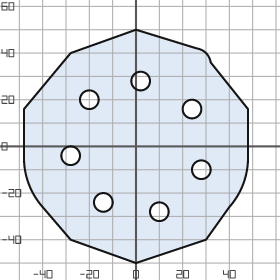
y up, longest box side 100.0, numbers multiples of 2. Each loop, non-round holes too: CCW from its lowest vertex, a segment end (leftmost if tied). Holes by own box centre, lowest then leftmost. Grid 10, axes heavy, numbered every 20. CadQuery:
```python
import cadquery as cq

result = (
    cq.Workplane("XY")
    .moveTo(0.0, -50.0)
    .lineTo(30.0, -40.0)
    .lineTo(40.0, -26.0)
    .threePointArc((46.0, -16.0), (48.0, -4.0))
    .lineTo(48.0, 16.0)
    .lineTo(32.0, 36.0)
    .threePointArc((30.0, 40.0), (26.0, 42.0))
    .lineTo(0.0, 50.0)
    .lineTo(-28.0, 40.0)
    .lineTo(-48.0, 16.0)
    .lineTo(-48.0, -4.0)
    .threePointArc((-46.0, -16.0), (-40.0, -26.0))
    .lineTo(-28.0, -40.0)
    .close()
    .moveTo(10.0, -28.0)
    .circle(4.0)
    .moveTo(-14.0, -24.0)
    .circle(4.0)
    .moveTo(28.0, -10.0)
    .circle(4.0)
    .moveTo(-28.0, -4.0)
    .circle(4.0)
    .moveTo(24.0, 16.0)
    .circle(4.0)
    .moveTo(-20.0, 20.0)
    .circle(4.0)
    .moveTo(2.0, 28.0)
    .circle(4.0)
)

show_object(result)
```